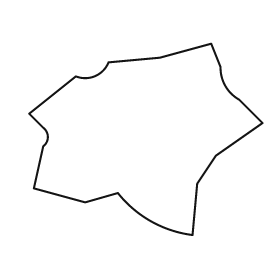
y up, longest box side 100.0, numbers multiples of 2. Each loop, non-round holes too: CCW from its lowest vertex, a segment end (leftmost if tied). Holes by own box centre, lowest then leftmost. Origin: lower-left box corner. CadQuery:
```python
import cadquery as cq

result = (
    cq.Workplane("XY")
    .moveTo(70.0, 0.0)
    .lineTo(72.0, 22.0)
    .lineTo(80.0, 34.0)
    .lineTo(100.0, 48.0)
    .lineTo(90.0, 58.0)
    .threePointArc((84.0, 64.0), (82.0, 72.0))
    .lineTo(78.0, 82.0)
    .lineTo(56.0, 76.0)
    .lineTo(34.0, 74.0)
    .threePointArc((28.0, 68.0), (20.0, 68.0))
    .lineTo(0.0, 52.0)
    .lineTo(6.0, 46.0)
    .threePointArc((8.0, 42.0), (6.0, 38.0))
    .lineTo(2.0, 20.0)
    .lineTo(24.0, 14.0)
    .lineTo(38.0, 18.0)
    .threePointArc((52.0, 6.0), (70.0, 0.0))
    .close()
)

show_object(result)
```